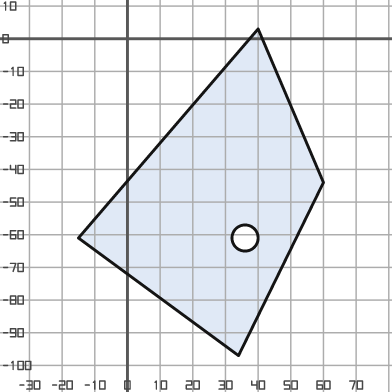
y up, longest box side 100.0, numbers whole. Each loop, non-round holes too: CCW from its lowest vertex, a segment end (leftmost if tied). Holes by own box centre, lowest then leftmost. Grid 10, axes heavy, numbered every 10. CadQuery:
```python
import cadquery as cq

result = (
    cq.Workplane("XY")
    .moveTo(34.0, -97.0)
    .lineTo(60.0, -44.0)
    .lineTo(40.0, 3.0)
    .lineTo(-15.0, -61.0)
    .close()
    .moveTo(36.0, -61.0)
    .circle(4.0)
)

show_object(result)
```